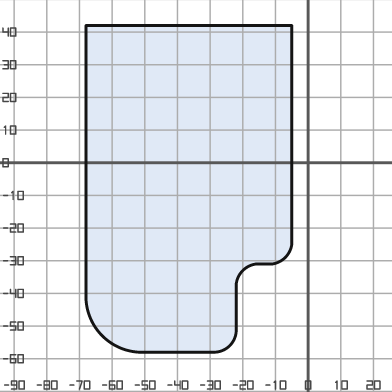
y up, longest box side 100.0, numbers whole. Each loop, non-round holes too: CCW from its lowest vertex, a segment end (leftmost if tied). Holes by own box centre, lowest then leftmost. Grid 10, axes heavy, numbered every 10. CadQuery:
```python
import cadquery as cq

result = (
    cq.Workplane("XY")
    .moveTo(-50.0, -58.0)
    .lineTo(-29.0, -58.0)
    .threePointArc((-24.0, -56.0), (-22.0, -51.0))
    .lineTo(-22.0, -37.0)
    .threePointArc((-20.0, -33.0), (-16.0, -31.0))
    .lineTo(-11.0, -31.0)
    .threePointArc((-7.0, -29.0), (-5.0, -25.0))
    .lineTo(-5.0, 42.0)
    .lineTo(-68.0, 42.0)
    .lineTo(-68.0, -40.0)
    .threePointArc((-63.0, -53.0), (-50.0, -58.0))
    .close()
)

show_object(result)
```